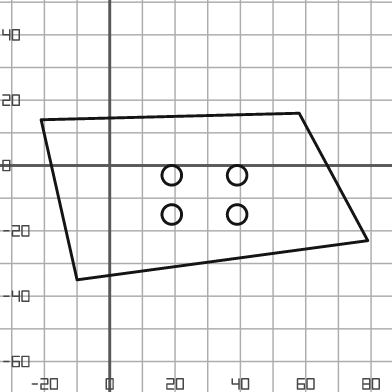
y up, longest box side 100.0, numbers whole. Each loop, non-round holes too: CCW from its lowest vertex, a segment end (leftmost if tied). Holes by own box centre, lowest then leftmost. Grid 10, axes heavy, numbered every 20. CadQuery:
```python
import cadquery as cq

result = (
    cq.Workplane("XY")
    .moveTo(-10.0, -35.0)
    .lineTo(79.0, -23.0)
    .lineTo(58.0, 16.0)
    .lineTo(-21.0, 14.0)
    .close()
    .moveTo(19.0, -15.0)
    .circle(3.0)
    .moveTo(39.0, -15.0)
    .circle(3.0)
    .moveTo(19.0, -3.0)
    .circle(3.0)
    .moveTo(39.0, -3.0)
    .circle(3.0)
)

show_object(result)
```